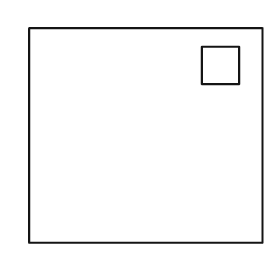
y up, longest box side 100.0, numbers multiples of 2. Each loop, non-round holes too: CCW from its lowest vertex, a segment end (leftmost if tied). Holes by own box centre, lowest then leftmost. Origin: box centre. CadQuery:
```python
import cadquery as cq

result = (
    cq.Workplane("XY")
    .moveTo(-50.0, -46.0)
    .lineTo(50.0, -46.0)
    .lineTo(50.0, 46.0)
    .lineTo(-50.0, 46.0)
    .close()
    .moveTo(24.0, 22.0)
    .lineTo(40.0, 22.0)
    .lineTo(40.0, 38.0)
    .lineTo(24.0, 38.0)
    .close()
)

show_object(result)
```